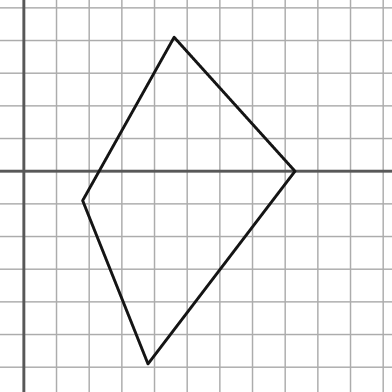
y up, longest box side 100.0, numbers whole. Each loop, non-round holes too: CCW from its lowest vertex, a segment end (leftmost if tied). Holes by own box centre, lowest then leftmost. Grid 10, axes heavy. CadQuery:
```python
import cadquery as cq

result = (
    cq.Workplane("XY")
    .moveTo(38.0, -59.0)
    .lineTo(83.0, 0.0)
    .lineTo(46.0, 41.0)
    .lineTo(18.0, -9.0)
    .close()
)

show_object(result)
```